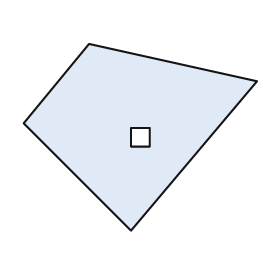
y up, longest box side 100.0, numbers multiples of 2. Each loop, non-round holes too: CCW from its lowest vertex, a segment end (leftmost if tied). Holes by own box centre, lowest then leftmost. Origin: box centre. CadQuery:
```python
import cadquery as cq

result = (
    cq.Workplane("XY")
    .moveTo(-4.0, -40.0)
    .lineTo(50.0, 24.0)
    .lineTo(-22.0, 40.0)
    .lineTo(-50.0, 6.0)
    .close()
    .moveTo(-4.0, -4.0)
    .lineTo(4.0, -4.0)
    .lineTo(4.0, 4.0)
    .lineTo(-4.0, 4.0)
    .close()
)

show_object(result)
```